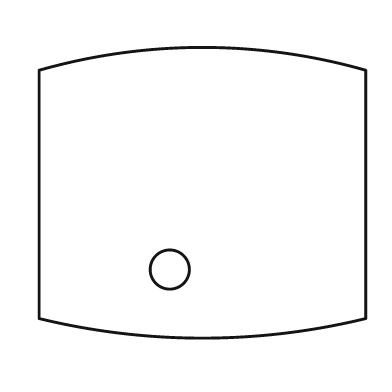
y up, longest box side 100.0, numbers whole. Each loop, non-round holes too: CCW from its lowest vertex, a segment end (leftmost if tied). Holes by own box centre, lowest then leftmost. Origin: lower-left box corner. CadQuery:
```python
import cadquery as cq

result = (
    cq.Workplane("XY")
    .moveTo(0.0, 6.0)
    .threePointArc((50.0, 0.0), (100.0, 6.0))
    .lineTo(100.0, 82.0)
    .threePointArc((50.0, 89.0), (0.0, 82.0))
    .close()
    .moveTo(40.0, 21.0)
    .circle(6.0)
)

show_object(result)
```